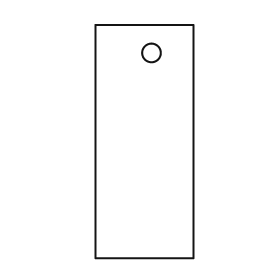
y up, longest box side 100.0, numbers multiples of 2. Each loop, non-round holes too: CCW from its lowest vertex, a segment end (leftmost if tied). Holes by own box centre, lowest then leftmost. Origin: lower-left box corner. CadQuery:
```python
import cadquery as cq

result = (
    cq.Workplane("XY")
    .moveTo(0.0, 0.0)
    .lineTo(42.0, 0.0)
    .lineTo(42.0, 100.0)
    .lineTo(0.0, 100.0)
    .close()
    .moveTo(24.0, 88.0)
    .circle(4.0)
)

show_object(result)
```